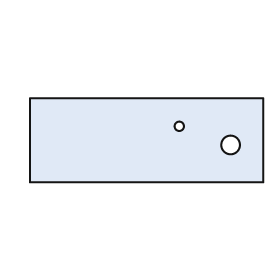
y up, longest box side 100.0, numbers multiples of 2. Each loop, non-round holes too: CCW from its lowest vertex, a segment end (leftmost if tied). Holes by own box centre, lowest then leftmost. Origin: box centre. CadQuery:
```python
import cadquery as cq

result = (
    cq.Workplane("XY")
    .moveTo(-50.0, -18.0)
    .lineTo(50.0, -18.0)
    .lineTo(50.0, 18.0)
    .lineTo(-50.0, 18.0)
    .close()
    .moveTo(36.0, -2.0)
    .circle(4.0)
    .moveTo(14.0, 6.0)
    .circle(2.0)
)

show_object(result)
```